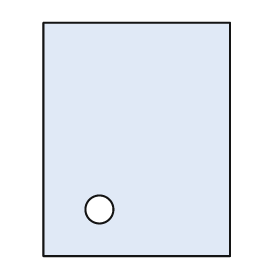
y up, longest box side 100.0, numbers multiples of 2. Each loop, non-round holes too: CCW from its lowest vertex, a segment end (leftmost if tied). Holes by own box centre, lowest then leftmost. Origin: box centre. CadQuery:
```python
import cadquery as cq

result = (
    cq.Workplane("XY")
    .moveTo(-40.0, -50.0)
    .lineTo(40.0, -50.0)
    .lineTo(40.0, 50.0)
    .lineTo(-40.0, 50.0)
    .close()
    .moveTo(-16.0, -30.0)
    .circle(6.0)
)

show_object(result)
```